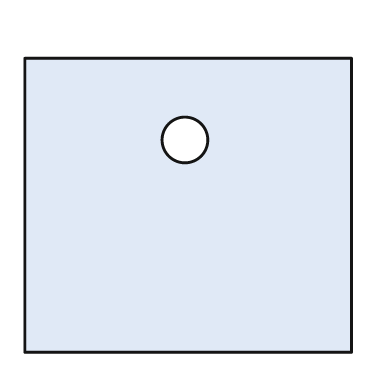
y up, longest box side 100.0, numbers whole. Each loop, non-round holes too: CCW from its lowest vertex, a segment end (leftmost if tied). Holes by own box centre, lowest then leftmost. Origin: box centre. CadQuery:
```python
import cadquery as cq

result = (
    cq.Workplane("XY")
    .moveTo(-50.0, -45.0)
    .lineTo(50.0, -45.0)
    .lineTo(50.0, 45.0)
    .lineTo(-50.0, 45.0)
    .close()
    .moveTo(-1.0, 20.0)
    .circle(7.0)
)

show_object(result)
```